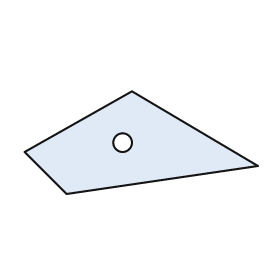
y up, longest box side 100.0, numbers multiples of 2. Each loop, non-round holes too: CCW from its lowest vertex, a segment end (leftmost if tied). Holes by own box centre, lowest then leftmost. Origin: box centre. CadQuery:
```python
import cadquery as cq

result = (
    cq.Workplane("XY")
    .moveTo(-32.0, -22.0)
    .lineTo(50.0, -10.0)
    .lineTo(-4.0, 22.0)
    .lineTo(-50.0, -4.0)
    .close()
    .moveTo(-8.0, 0.0)
    .circle(4.0)
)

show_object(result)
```